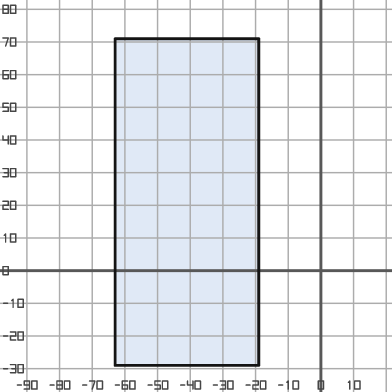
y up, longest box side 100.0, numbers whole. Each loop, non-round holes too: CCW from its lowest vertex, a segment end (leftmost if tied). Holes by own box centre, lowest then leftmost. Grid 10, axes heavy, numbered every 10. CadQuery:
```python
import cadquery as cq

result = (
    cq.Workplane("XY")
    .moveTo(-63.0, -29.0)
    .lineTo(-19.0, -29.0)
    .lineTo(-19.0, 71.0)
    .lineTo(-63.0, 71.0)
    .close()
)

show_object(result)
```